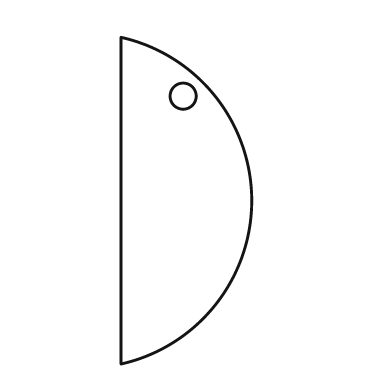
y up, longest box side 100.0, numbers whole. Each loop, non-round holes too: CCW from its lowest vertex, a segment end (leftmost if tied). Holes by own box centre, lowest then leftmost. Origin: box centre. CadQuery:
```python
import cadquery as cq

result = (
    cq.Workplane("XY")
    .moveTo(-20.0, -50.0)
    .threePointArc((20.0, 0.0), (-20.0, 50.0))
    .close()
    .moveTo(-1.0, 32.0)
    .circle(4.0)
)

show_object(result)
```